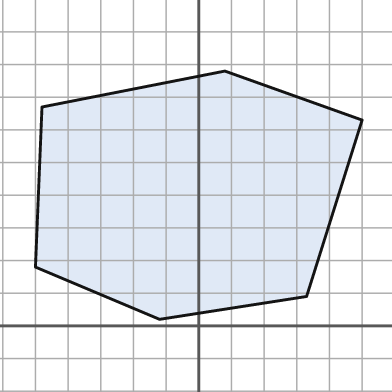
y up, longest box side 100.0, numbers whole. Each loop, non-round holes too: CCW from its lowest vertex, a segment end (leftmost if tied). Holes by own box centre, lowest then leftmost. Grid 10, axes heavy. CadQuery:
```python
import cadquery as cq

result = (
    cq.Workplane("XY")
    .moveTo(-12.0, 2.0)
    .lineTo(33.0, 9.0)
    .lineTo(50.0, 63.0)
    .lineTo(8.0, 78.0)
    .lineTo(-48.0, 67.0)
    .lineTo(-50.0, 18.0)
    .close()
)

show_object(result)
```